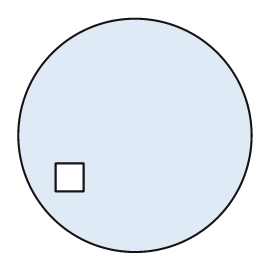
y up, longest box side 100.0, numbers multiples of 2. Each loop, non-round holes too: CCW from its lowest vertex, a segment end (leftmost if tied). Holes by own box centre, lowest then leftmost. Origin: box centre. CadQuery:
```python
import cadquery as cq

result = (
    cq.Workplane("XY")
    .moveTo(0.0, 0.0)
    .circle(50.0)
    .moveTo(-34.0, -24.0)
    .lineTo(-22.0, -24.0)
    .lineTo(-22.0, -12.0)
    .lineTo(-34.0, -12.0)
    .close()
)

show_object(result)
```